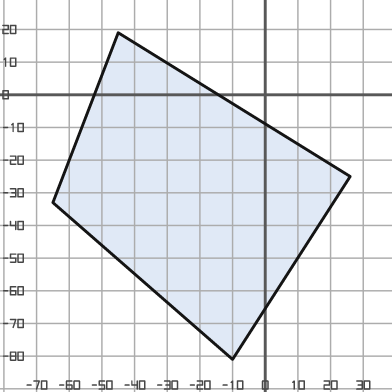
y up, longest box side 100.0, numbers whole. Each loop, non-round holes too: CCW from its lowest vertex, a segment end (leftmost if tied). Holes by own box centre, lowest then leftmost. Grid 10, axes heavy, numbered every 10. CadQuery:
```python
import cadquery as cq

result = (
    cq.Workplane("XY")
    .moveTo(-10.0, -81.0)
    .lineTo(26.0, -25.0)
    .lineTo(-45.0, 19.0)
    .lineTo(-65.0, -33.0)
    .close()
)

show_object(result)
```